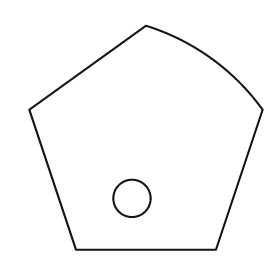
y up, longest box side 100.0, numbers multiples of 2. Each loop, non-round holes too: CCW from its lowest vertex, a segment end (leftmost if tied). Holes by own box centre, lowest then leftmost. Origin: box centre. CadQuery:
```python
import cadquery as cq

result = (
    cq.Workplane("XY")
    .moveTo(-30.0, -48.0)
    .lineTo(30.0, -48.0)
    .lineTo(50.0, 12.0)
    .threePointArc((28.0, 34.0), (0.0, 48.0))
    .lineTo(-50.0, 12.0)
    .close()
    .moveTo(-6.0, -26.0)
    .circle(8.0)
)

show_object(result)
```